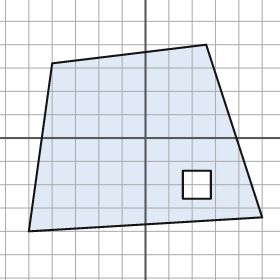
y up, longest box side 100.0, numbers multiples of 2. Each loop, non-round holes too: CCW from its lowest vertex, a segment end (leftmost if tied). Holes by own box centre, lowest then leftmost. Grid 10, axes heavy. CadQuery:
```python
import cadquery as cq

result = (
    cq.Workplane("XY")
    .moveTo(-50.0, -40.0)
    .lineTo(50.0, -34.0)
    .lineTo(26.0, 40.0)
    .lineTo(-40.0, 32.0)
    .close()
    .moveTo(16.0, -26.0)
    .lineTo(28.0, -26.0)
    .lineTo(28.0, -14.0)
    .lineTo(16.0, -14.0)
    .close()
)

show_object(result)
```